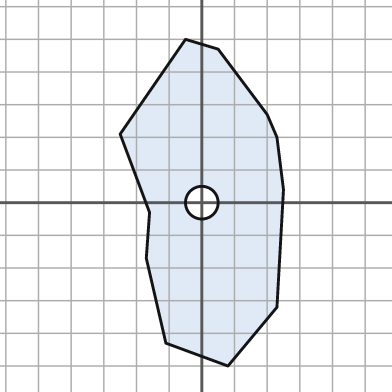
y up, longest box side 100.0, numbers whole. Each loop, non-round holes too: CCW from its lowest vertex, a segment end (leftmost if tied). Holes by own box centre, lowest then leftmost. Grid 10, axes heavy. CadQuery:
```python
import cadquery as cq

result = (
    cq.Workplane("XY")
    .moveTo(8.0, -50.0)
    .lineTo(23.0, -32.0)
    .lineTo(25.0, 4.0)
    .lineTo(23.0, 20.0)
    .lineTo(20.0, 27.0)
    .lineTo(5.0, 47.0)
    .lineTo(-5.0, 50.0)
    .lineTo(-25.0, 21.0)
    .lineTo(-16.0, -3.0)
    .lineTo(-17.0, -17.0)
    .lineTo(-11.0, -43.0)
    .close()
    .moveTo(0.0, 0.0)
    .circle(5.0)
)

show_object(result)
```